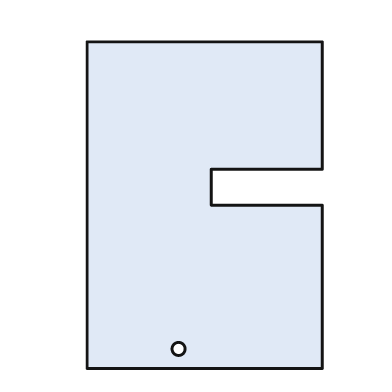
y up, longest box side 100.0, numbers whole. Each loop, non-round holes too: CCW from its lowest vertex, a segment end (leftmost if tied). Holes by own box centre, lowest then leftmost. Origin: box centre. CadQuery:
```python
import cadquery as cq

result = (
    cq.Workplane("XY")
    .moveTo(-36.0, -50.0)
    .lineTo(36.0, -50.0)
    .lineTo(36.0, 0.0)
    .lineTo(2.0, 0.0)
    .lineTo(2.0, 11.0)
    .lineTo(36.0, 11.0)
    .lineTo(36.0, 50.0)
    .lineTo(-36.0, 50.0)
    .close()
    .moveTo(-8.0, -44.0)
    .circle(2.0)
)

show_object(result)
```